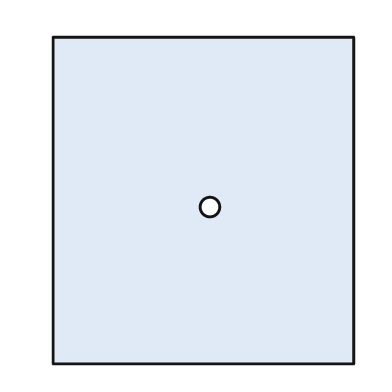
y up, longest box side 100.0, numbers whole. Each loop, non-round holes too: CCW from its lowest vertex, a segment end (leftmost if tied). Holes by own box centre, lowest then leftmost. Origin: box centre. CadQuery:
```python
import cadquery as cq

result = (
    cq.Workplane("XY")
    .moveTo(-46.0, -50.0)
    .lineTo(46.0, -50.0)
    .lineTo(46.0, 50.0)
    .lineTo(-46.0, 50.0)
    .close()
    .moveTo(2.0, -2.0)
    .circle(3.0)
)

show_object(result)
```